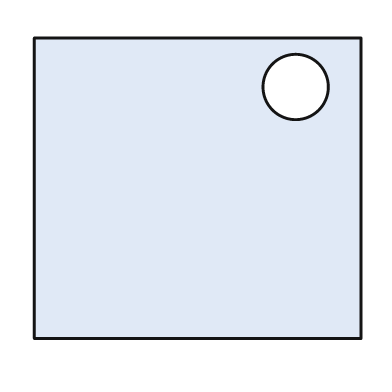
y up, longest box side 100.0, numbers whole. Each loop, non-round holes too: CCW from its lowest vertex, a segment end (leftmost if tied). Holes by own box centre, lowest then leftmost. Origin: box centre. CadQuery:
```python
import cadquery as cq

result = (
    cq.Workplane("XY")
    .moveTo(-50.0, -46.0)
    .lineTo(50.0, -46.0)
    .lineTo(50.0, 46.0)
    .lineTo(-50.0, 46.0)
    .close()
    .moveTo(30.0, 31.0)
    .circle(10.0)
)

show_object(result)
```